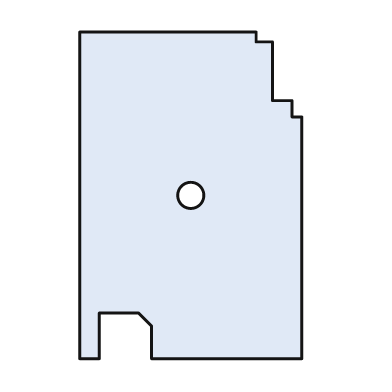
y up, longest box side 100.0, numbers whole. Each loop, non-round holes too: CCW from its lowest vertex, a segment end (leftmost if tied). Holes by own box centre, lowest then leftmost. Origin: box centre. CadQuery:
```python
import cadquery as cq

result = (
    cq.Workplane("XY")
    .moveTo(-34.0, -50.0)
    .lineTo(-28.0, -50.0)
    .lineTo(-28.0, -36.0)
    .lineTo(-16.0, -36.0)
    .lineTo(-12.0, -40.0)
    .lineTo(-12.0, -50.0)
    .lineTo(34.0, -50.0)
    .lineTo(34.0, 24.0)
    .lineTo(31.0, 24.0)
    .lineTo(31.0, 29.0)
    .lineTo(25.0, 29.0)
    .lineTo(25.0, 47.0)
    .lineTo(20.0, 47.0)
    .lineTo(20.0, 50.0)
    .lineTo(-34.0, 50.0)
    .close()
    .moveTo(0.0, 0.0)
    .circle(4.0)
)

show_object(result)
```